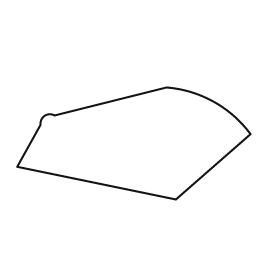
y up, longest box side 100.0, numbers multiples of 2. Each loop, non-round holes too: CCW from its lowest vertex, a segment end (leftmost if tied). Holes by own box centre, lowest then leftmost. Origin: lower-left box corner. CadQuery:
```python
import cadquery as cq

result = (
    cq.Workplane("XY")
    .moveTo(68.0, 0.0)
    .lineTo(100.0, 28.0)
    .threePointArc((84.0, 42.0), (64.0, 48.0))
    .lineTo(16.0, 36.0)
    .threePointArc((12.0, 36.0), (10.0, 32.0))
    .lineTo(0.0, 14.0)
    .close()
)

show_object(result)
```